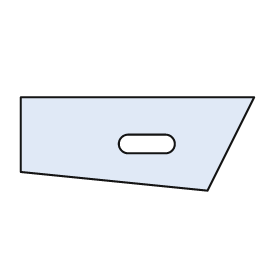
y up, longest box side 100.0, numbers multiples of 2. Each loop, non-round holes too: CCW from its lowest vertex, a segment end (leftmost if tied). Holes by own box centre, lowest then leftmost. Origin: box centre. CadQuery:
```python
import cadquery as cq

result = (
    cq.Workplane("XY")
    .moveTo(30.0, -20.0)
    .lineTo(50.0, 20.0)
    .lineTo(-50.0, 20.0)
    .lineTo(-50.0, -12.0)
    .close()
    .moveTo(-4.0, -4.0)
    .lineTo(12.0, -4.0)
    .threePointArc((16.0, 0.0), (12.0, 4.0))
    .lineTo(-4.0, 4.0)
    .threePointArc((-8.0, 0.0), (-4.0, -4.0))
    .close()
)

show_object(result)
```